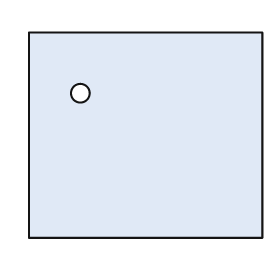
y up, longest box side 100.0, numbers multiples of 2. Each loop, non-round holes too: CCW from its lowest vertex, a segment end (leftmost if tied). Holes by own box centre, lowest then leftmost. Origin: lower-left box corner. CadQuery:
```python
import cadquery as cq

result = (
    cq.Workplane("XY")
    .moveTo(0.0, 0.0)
    .lineTo(100.0, 0.0)
    .lineTo(100.0, 88.0)
    .lineTo(0.0, 88.0)
    .close()
    .moveTo(22.0, 62.0)
    .circle(4.0)
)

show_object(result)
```